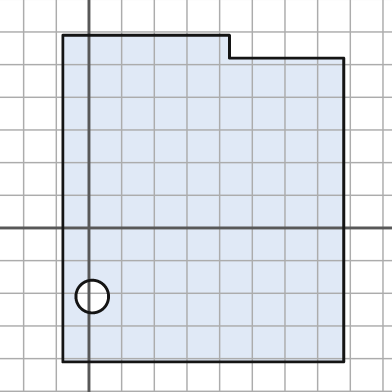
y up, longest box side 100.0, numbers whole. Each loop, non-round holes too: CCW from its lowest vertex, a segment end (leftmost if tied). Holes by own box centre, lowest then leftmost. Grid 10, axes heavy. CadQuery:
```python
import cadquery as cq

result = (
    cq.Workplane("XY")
    .moveTo(-8.0, -41.0)
    .lineTo(78.0, -41.0)
    .lineTo(78.0, 52.0)
    .lineTo(43.0, 52.0)
    .lineTo(43.0, 59.0)
    .lineTo(-8.0, 59.0)
    .close()
    .moveTo(1.0, -21.0)
    .circle(5.0)
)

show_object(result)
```